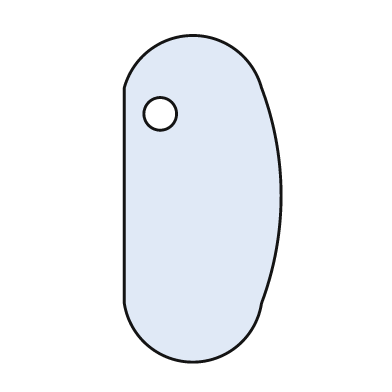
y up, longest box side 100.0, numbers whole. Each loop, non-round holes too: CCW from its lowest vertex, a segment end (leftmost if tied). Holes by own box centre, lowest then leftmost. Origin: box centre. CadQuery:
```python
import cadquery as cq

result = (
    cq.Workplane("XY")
    .moveTo(-24.0, -32.0)
    .threePointArc((-3.0, -50.0), (18.0, -32.0))
    .threePointArc((24.0, 1.0), (18.0, 34.0))
    .threePointArc((-3.0, 50.0), (-24.0, 34.0))
    .close()
    .moveTo(-13.0, 26.0)
    .circle(5.0)
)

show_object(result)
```